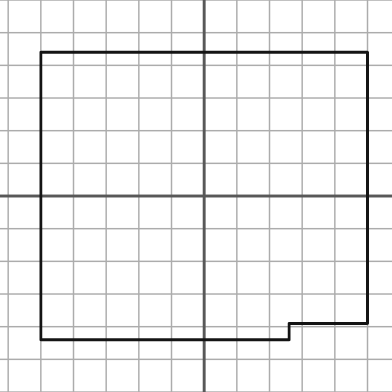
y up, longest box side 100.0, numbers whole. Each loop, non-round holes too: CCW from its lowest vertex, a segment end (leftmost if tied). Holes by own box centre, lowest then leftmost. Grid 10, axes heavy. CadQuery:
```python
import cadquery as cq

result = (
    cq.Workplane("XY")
    .moveTo(-50.0, -44.0)
    .lineTo(26.0, -44.0)
    .lineTo(26.0, -39.0)
    .lineTo(50.0, -39.0)
    .lineTo(50.0, 44.0)
    .lineTo(-50.0, 44.0)
    .close()
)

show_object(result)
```